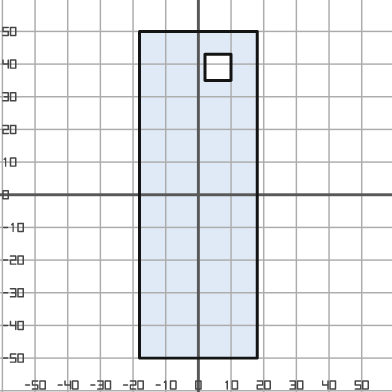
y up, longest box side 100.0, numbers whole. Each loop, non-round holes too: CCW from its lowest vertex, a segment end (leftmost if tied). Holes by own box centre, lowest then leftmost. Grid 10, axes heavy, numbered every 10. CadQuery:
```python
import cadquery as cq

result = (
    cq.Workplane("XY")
    .moveTo(-18.0, -50.0)
    .lineTo(18.0, -50.0)
    .lineTo(18.0, 50.0)
    .lineTo(-18.0, 50.0)
    .close()
    .moveTo(2.0, 35.0)
    .lineTo(10.0, 35.0)
    .lineTo(10.0, 43.0)
    .lineTo(2.0, 43.0)
    .close()
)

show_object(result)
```